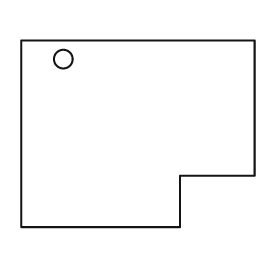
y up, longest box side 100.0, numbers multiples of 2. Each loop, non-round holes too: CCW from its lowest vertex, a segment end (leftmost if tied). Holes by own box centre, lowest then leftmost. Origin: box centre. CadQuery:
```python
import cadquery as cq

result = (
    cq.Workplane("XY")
    .moveTo(-50.0, -40.0)
    .lineTo(18.0, -40.0)
    .lineTo(18.0, -18.0)
    .lineTo(50.0, -18.0)
    .lineTo(50.0, 40.0)
    .lineTo(-50.0, 40.0)
    .close()
    .moveTo(-32.0, 32.0)
    .circle(4.0)
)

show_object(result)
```